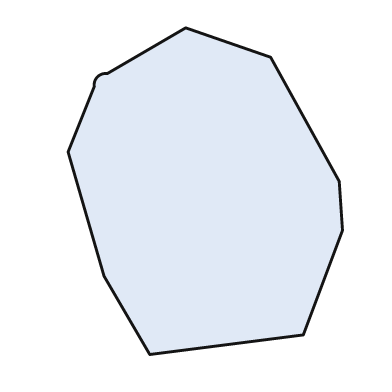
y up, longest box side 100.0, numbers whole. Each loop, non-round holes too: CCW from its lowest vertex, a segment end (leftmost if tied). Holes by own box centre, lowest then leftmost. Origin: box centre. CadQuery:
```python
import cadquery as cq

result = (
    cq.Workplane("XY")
    .moveTo(-17.0, -50.0)
    .lineTo(30.0, -44.0)
    .lineTo(42.0, -12.0)
    .lineTo(41.0, 3.0)
    .lineTo(20.0, 41.0)
    .lineTo(-6.0, 50.0)
    .lineTo(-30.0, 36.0)
    .threePointArc((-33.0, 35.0), (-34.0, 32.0))
    .lineTo(-42.0, 12.0)
    .lineTo(-31.0, -26.0)
    .close()
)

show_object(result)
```